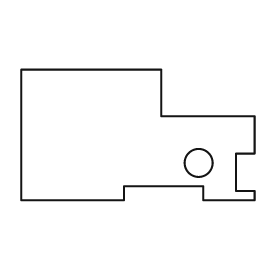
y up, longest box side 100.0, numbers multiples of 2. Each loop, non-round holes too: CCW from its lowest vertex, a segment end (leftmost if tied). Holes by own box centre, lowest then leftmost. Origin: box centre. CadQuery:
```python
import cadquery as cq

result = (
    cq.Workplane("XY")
    .moveTo(-50.0, -28.0)
    .lineTo(-6.0, -28.0)
    .lineTo(-6.0, -22.0)
    .lineTo(28.0, -22.0)
    .lineTo(28.0, -28.0)
    .lineTo(50.0, -28.0)
    .lineTo(50.0, -24.0)
    .lineTo(42.0, -24.0)
    .lineTo(42.0, -8.0)
    .lineTo(50.0, -8.0)
    .lineTo(50.0, 8.0)
    .lineTo(10.0, 8.0)
    .lineTo(10.0, 28.0)
    .lineTo(-50.0, 28.0)
    .close()
    .moveTo(26.0, -12.0)
    .circle(6.0)
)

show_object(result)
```